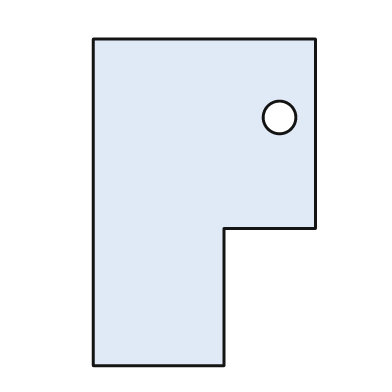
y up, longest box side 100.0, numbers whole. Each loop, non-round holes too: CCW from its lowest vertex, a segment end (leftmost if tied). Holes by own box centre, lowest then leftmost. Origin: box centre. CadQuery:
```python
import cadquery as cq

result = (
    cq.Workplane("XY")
    .moveTo(-34.0, -50.0)
    .lineTo(6.0, -50.0)
    .lineTo(6.0, -8.0)
    .lineTo(34.0, -8.0)
    .lineTo(34.0, 50.0)
    .lineTo(-34.0, 50.0)
    .close()
    .moveTo(23.0, 26.0)
    .circle(5.0)
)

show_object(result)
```